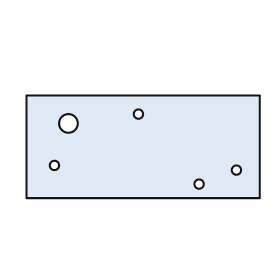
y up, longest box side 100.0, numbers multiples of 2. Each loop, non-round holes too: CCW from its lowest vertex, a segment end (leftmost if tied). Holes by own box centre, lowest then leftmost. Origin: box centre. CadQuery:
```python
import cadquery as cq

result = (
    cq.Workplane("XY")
    .moveTo(-50.0, -22.0)
    .lineTo(50.0, -22.0)
    .lineTo(50.0, 22.0)
    .lineTo(-50.0, 22.0)
    .close()
    .moveTo(24.0, -16.0)
    .circle(2.0)
    .moveTo(40.0, -10.0)
    .circle(2.0)
    .moveTo(-38.0, -8.0)
    .circle(2.0)
    .moveTo(-32.0, 10.0)
    .circle(4.0)
    .moveTo(-2.0, 14.0)
    .circle(2.0)
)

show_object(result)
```